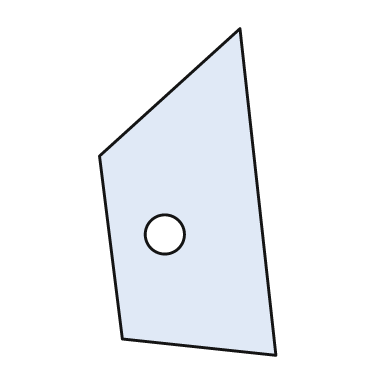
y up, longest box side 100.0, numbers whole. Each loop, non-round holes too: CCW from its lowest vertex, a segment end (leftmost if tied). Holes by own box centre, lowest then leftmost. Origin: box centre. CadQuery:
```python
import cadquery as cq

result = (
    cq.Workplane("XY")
    .moveTo(27.0, -50.0)
    .lineTo(16.0, 50.0)
    .lineTo(-27.0, 11.0)
    .lineTo(-20.0, -45.0)
    .close()
    .moveTo(-7.0, -13.0)
    .circle(6.0)
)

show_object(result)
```